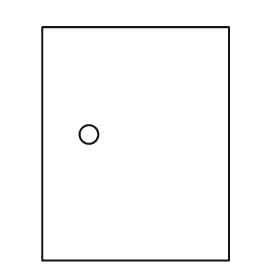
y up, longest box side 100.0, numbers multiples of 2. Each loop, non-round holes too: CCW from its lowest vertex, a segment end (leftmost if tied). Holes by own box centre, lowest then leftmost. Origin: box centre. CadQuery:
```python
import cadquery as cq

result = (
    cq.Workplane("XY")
    .moveTo(-40.0, -50.0)
    .lineTo(40.0, -50.0)
    .lineTo(40.0, 50.0)
    .lineTo(-40.0, 50.0)
    .close()
    .moveTo(-20.0, 4.0)
    .circle(4.0)
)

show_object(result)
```